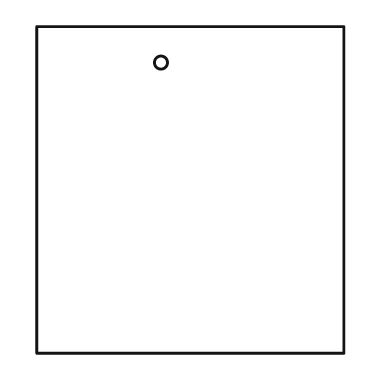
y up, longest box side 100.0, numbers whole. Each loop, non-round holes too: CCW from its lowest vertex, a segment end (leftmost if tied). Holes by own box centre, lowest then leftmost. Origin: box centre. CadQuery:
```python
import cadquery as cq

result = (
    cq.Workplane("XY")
    .moveTo(-47.0, -50.0)
    .lineTo(47.0, -50.0)
    .lineTo(47.0, 50.0)
    .lineTo(-47.0, 50.0)
    .close()
    .moveTo(-9.0, 39.0)
    .circle(2.0)
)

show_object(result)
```